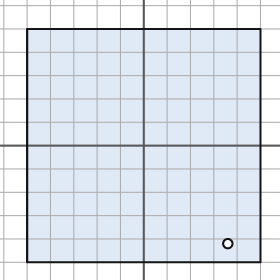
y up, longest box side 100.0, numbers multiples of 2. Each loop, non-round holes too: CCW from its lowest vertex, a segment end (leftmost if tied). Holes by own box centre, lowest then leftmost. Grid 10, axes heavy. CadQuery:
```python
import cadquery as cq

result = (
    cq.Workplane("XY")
    .moveTo(-50.0, -50.0)
    .lineTo(50.0, -50.0)
    .lineTo(50.0, 50.0)
    .lineTo(-50.0, 50.0)
    .close()
    .moveTo(36.0, -42.0)
    .circle(2.0)
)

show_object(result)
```